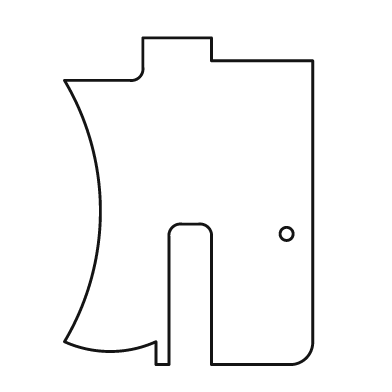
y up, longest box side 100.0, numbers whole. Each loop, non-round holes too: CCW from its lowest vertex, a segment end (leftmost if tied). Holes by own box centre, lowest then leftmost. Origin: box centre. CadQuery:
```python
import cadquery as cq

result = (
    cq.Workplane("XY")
    .moveTo(-10.0, -50.0)
    .lineTo(-6.0, -50.0)
    .lineTo(-6.0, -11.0)
    .threePointArc((-5.0, -8.0), (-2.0, -7.0))
    .lineTo(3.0, -7.0)
    .threePointArc((6.0, -8.0), (7.0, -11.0))
    .lineTo(7.0, -50.0)
    .lineTo(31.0, -50.0)
    .threePointArc((36.0, -48.0), (38.0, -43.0))
    .lineTo(38.0, 43.0)
    .lineTo(7.0, 43.0)
    .lineTo(7.0, 50.0)
    .lineTo(-14.0, 50.0)
    .lineTo(-14.0, 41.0)
    .threePointArc((-15.0, 38.0), (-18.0, 37.0))
    .lineTo(-38.0, 37.0)
    .threePointArc((-27.0, -3.0), (-38.0, -43.0))
    .threePointArc((-24.0, -46.0), (-10.0, -43.0))
    .close()
    .moveTo(30.0, -10.0)
    .circle(2.0)
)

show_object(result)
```